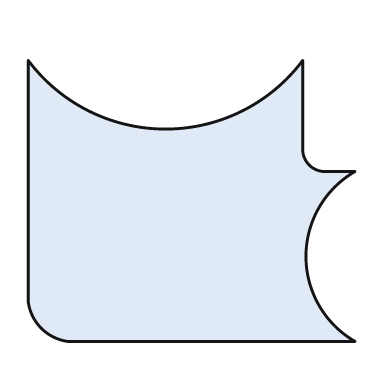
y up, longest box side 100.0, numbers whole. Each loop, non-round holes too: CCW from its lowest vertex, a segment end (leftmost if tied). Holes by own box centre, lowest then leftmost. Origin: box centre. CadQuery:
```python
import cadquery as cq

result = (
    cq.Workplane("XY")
    .moveTo(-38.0, -43.0)
    .lineTo(50.0, -43.0)
    .threePointArc((35.0, -17.0), (50.0, 9.0))
    .lineTo(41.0, 9.0)
    .threePointArc((36.0, 11.0), (34.0, 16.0))
    .lineTo(34.0, 43.0)
    .threePointArc((-8.0, 22.0), (-50.0, 43.0))
    .lineTo(-50.0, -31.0)
    .threePointArc((-46.0, -39.0), (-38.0, -43.0))
    .close()
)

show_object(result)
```